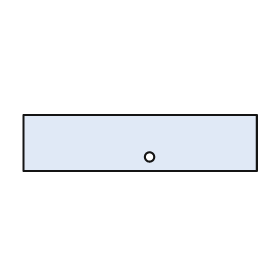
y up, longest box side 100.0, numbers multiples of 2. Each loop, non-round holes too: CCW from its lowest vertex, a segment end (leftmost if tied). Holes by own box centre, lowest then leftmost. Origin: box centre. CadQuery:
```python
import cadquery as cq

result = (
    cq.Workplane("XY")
    .moveTo(-50.0, -12.0)
    .lineTo(50.0, -12.0)
    .lineTo(50.0, 12.0)
    .lineTo(-50.0, 12.0)
    .close()
    .moveTo(4.0, -6.0)
    .circle(2.0)
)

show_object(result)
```